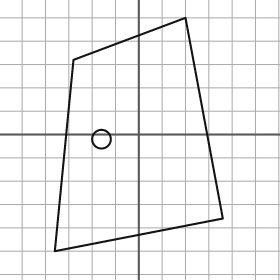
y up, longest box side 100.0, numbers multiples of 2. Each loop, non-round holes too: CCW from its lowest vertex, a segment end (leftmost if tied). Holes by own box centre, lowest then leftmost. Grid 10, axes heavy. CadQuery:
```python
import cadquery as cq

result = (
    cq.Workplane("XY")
    .moveTo(-36.0, -50.0)
    .lineTo(36.0, -36.0)
    .lineTo(20.0, 50.0)
    .lineTo(-28.0, 32.0)
    .close()
    .moveTo(-16.0, -2.0)
    .circle(4.0)
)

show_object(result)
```